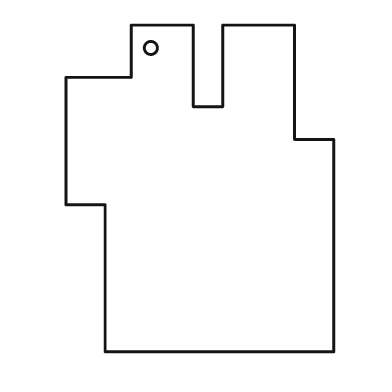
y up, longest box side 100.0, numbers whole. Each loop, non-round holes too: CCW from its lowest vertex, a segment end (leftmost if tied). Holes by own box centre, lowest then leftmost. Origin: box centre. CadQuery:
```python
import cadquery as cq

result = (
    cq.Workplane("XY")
    .moveTo(-29.0, -50.0)
    .lineTo(41.0, -50.0)
    .lineTo(41.0, 15.0)
    .lineTo(29.0, 15.0)
    .lineTo(29.0, 50.0)
    .lineTo(7.0, 50.0)
    .lineTo(7.0, 25.0)
    .lineTo(-2.0, 25.0)
    .lineTo(-2.0, 50.0)
    .lineTo(-21.0, 50.0)
    .lineTo(-21.0, 34.0)
    .lineTo(-41.0, 34.0)
    .lineTo(-41.0, -5.0)
    .lineTo(-29.0, -5.0)
    .close()
    .moveTo(-15.0, 43.0)
    .circle(2.0)
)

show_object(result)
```